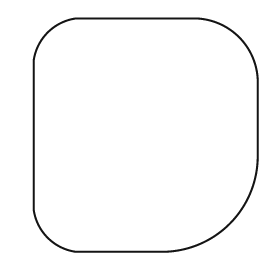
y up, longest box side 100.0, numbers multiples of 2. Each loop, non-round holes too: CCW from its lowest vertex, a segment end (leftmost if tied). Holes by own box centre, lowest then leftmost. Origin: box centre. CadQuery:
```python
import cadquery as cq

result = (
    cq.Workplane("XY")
    .moveTo(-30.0, -50.0)
    .lineTo(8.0, -50.0)
    .threePointArc((36.0, -38.0), (48.0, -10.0))
    .lineTo(48.0, 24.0)
    .threePointArc((40.0, 42.0), (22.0, 50.0))
    .lineTo(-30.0, 50.0)
    .threePointArc((-42.0, 44.0), (-48.0, 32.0))
    .lineTo(-48.0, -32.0)
    .threePointArc((-42.0, -44.0), (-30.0, -50.0))
    .close()
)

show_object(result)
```